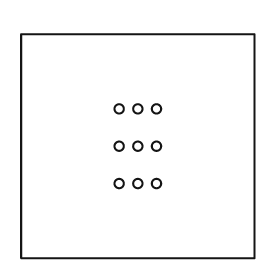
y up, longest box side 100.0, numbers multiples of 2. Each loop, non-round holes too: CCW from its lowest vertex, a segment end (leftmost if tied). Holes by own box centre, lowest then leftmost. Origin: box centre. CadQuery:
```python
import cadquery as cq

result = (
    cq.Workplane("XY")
    .moveTo(-50.0, -48.0)
    .lineTo(50.0, -48.0)
    .lineTo(50.0, 48.0)
    .lineTo(-50.0, 48.0)
    .close()
    .moveTo(-8.0, -16.0)
    .circle(2.0)
    .moveTo(0.0, -16.0)
    .circle(2.0)
    .moveTo(8.0, -16.0)
    .circle(2.0)
    .moveTo(-8.0, 0.0)
    .circle(2.0)
    .moveTo(0.0, 0.0)
    .circle(2.0)
    .moveTo(8.0, 0.0)
    .circle(2.0)
    .moveTo(-8.0, 16.0)
    .circle(2.0)
    .moveTo(0.0, 16.0)
    .circle(2.0)
    .moveTo(8.0, 16.0)
    .circle(2.0)
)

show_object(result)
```